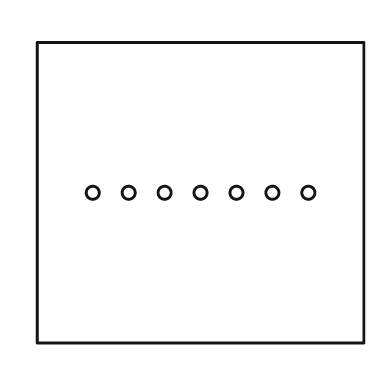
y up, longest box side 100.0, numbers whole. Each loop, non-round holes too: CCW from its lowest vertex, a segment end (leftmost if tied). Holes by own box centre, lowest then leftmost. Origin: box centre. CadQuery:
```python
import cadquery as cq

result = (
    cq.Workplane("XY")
    .moveTo(-50.0, -46.0)
    .lineTo(50.0, -46.0)
    .lineTo(50.0, 46.0)
    .lineTo(-50.0, 46.0)
    .close()
    .moveTo(-33.0, 0.0)
    .circle(2.0)
    .moveTo(-22.0, 0.0)
    .circle(2.0)
    .moveTo(-11.0, 0.0)
    .circle(2.0)
    .moveTo(0.0, 0.0)
    .circle(2.0)
    .moveTo(11.0, 0.0)
    .circle(2.0)
    .moveTo(22.0, 0.0)
    .circle(2.0)
    .moveTo(33.0, 0.0)
    .circle(2.0)
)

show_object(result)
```